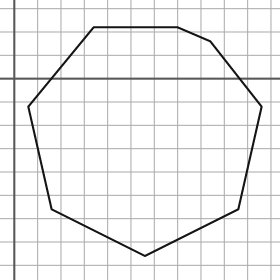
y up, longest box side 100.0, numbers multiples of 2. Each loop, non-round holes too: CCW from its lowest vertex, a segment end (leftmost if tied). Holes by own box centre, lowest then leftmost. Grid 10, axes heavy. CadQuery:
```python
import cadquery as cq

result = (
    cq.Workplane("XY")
    .moveTo(56.0, -76.0)
    .lineTo(96.0, -56.0)
    .lineTo(106.0, -12.0)
    .lineTo(84.0, 16.0)
    .lineTo(70.0, 22.0)
    .lineTo(34.0, 22.0)
    .lineTo(6.0, -12.0)
    .lineTo(16.0, -56.0)
    .close()
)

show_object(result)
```